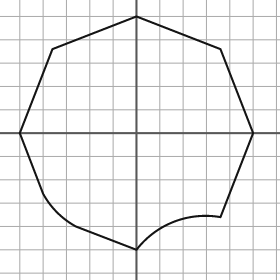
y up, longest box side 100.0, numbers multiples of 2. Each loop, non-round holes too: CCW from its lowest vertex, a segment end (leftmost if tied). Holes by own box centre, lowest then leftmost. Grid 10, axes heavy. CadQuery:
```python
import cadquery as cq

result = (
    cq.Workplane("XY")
    .moveTo(0.0, -50.0)
    .threePointArc((16.0, -38.0), (36.0, -36.0))
    .lineTo(50.0, 0.0)
    .lineTo(36.0, 36.0)
    .lineTo(0.0, 50.0)
    .lineTo(-36.0, 36.0)
    .lineTo(-50.0, 0.0)
    .lineTo(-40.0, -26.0)
    .threePointArc((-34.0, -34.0), (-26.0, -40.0))
    .close()
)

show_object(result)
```